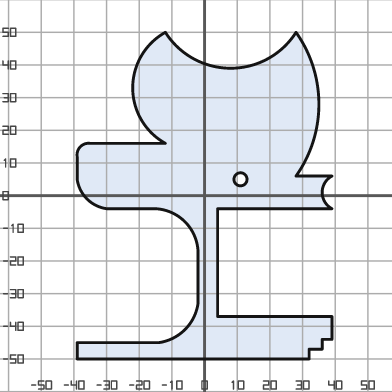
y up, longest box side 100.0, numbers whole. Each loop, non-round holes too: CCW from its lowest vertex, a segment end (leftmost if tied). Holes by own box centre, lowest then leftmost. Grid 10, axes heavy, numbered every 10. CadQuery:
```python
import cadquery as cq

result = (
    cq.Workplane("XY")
    .moveTo(-39.0, -50.0)
    .lineTo(32.0, -50.0)
    .lineTo(32.0, -47.0)
    .lineTo(36.0, -47.0)
    .lineTo(36.0, -44.0)
    .lineTo(39.0, -44.0)
    .lineTo(39.0, -37.0)
    .lineTo(4.0, -37.0)
    .lineTo(4.0, -4.0)
    .lineTo(39.0, -4.0)
    .threePointArc((36.0, 1.0), (39.0, 6.0))
    .lineTo(28.0, 6.0)
    .threePointArc((35.0, 28.0), (28.0, 50.0))
    .threePointArc((8.0, 39.0), (-12.0, 50.0))
    .threePointArc((-22.0, 33.0), (-12.0, 16.0))
    .lineTo(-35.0, 16.0)
    .threePointArc((-38.0, 15.0), (-39.0, 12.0))
    .lineTo(-39.0, 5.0)
    .threePointArc((-36.0, -1.0), (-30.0, -4.0))
    .lineTo(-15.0, -4.0)
    .threePointArc((-6.0, -8.0), (-2.0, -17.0))
    .lineTo(-2.0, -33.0)
    .threePointArc((-6.0, -41.0), (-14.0, -45.0))
    .lineTo(-39.0, -45.0)
    .close()
    .moveTo(11.0, 5.0)
    .circle(2.0)
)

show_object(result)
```